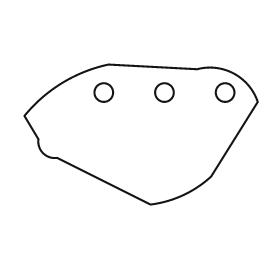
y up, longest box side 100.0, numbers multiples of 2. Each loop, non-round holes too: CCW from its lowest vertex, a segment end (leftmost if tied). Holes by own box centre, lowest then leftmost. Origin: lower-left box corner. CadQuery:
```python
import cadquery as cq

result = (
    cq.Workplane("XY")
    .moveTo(54.0, 0.0)
    .threePointArc((68.0, 4.0), (80.0, 12.0))
    .lineTo(100.0, 44.0)
    .threePointArc((90.0, 56.0), (74.0, 58.0))
    .lineTo(36.0, 60.0)
    .threePointArc((16.0, 52.0), (0.0, 38.0))
    .lineTo(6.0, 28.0)
    .threePointArc((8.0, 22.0), (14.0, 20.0))
    .close()
    .moveTo(34.0, 48.0)
    .circle(4.0)
    .moveTo(60.0, 48.0)
    .circle(4.0)
    .moveTo(86.0, 48.0)
    .circle(4.0)
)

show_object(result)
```